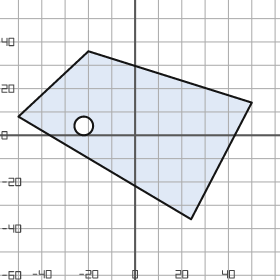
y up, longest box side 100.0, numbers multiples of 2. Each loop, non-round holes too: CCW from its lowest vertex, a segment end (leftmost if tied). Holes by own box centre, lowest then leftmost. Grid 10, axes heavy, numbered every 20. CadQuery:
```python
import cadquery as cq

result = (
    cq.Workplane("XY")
    .moveTo(24.0, -36.0)
    .lineTo(50.0, 14.0)
    .lineTo(-20.0, 36.0)
    .lineTo(-50.0, 8.0)
    .close()
    .moveTo(-22.0, 4.0)
    .circle(4.0)
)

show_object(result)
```